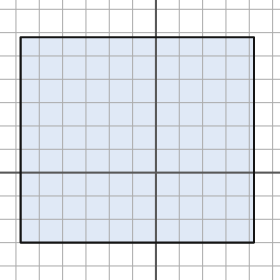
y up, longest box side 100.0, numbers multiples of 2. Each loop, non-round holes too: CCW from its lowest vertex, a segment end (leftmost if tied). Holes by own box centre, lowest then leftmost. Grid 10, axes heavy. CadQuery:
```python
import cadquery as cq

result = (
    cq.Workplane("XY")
    .moveTo(-58.0, -30.0)
    .lineTo(42.0, -30.0)
    .lineTo(42.0, 58.0)
    .lineTo(-58.0, 58.0)
    .close()
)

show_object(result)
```